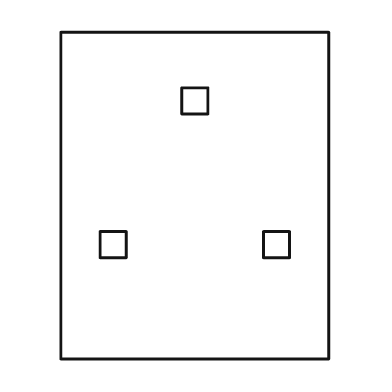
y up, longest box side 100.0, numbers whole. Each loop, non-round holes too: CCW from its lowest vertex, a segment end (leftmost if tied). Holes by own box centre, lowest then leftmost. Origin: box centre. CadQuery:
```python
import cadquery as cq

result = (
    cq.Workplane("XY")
    .moveTo(-41.0, -50.0)
    .lineTo(41.0, -50.0)
    .lineTo(41.0, 50.0)
    .lineTo(-41.0, 50.0)
    .close()
    .moveTo(-29.0, -19.0)
    .lineTo(-21.0, -19.0)
    .lineTo(-21.0, -11.0)
    .lineTo(-29.0, -11.0)
    .close()
    .moveTo(21.0, -19.0)
    .lineTo(29.0, -19.0)
    .lineTo(29.0, -11.0)
    .lineTo(21.0, -11.0)
    .close()
    .moveTo(-4.0, 25.0)
    .lineTo(4.0, 25.0)
    .lineTo(4.0, 33.0)
    .lineTo(-4.0, 33.0)
    .close()
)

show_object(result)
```